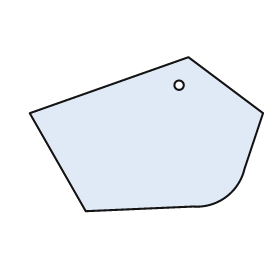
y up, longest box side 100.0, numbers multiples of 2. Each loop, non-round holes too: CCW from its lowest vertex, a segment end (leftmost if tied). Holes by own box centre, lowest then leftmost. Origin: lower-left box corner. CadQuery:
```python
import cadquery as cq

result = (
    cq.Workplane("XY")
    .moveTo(24.0, 0.0)
    .lineTo(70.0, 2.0)
    .threePointArc((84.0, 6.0), (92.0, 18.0))
    .lineTo(100.0, 42.0)
    .lineTo(68.0, 66.0)
    .lineTo(0.0, 42.0)
    .close()
    .moveTo(64.0, 54.0)
    .circle(2.0)
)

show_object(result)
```